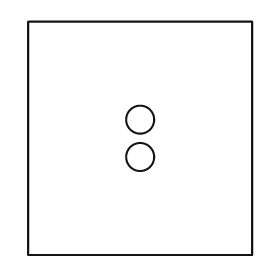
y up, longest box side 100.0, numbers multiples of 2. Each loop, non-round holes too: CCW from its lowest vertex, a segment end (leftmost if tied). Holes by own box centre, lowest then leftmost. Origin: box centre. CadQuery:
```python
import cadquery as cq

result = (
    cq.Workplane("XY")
    .moveTo(-48.0, -50.0)
    .lineTo(48.0, -50.0)
    .lineTo(48.0, 50.0)
    .lineTo(-48.0, 50.0)
    .close()
    .moveTo(0.0, -8.0)
    .circle(6.0)
    .moveTo(0.0, 8.0)
    .circle(6.0)
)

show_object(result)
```